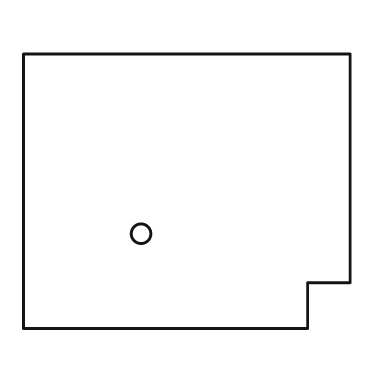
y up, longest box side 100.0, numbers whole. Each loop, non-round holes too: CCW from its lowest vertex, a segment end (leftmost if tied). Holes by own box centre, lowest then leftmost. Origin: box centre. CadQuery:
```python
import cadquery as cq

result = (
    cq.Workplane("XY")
    .moveTo(-50.0, -42.0)
    .lineTo(37.0, -42.0)
    .lineTo(37.0, -28.0)
    .lineTo(50.0, -28.0)
    .lineTo(50.0, 42.0)
    .lineTo(-50.0, 42.0)
    .close()
    .moveTo(-14.0, -13.0)
    .circle(3.0)
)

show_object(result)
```